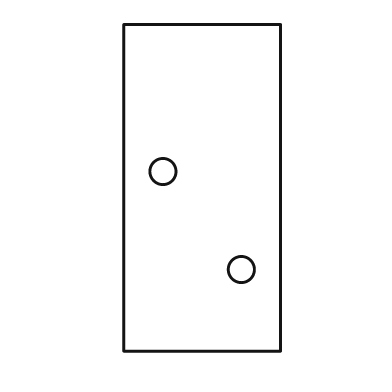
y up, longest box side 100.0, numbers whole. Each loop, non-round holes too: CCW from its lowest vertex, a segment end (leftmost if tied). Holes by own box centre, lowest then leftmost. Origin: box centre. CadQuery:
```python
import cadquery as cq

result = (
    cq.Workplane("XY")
    .moveTo(-24.0, -50.0)
    .lineTo(24.0, -50.0)
    .lineTo(24.0, 50.0)
    .lineTo(-24.0, 50.0)
    .close()
    .moveTo(12.0, -25.0)
    .circle(4.0)
    .moveTo(-12.0, 5.0)
    .circle(4.0)
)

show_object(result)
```